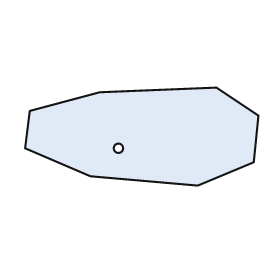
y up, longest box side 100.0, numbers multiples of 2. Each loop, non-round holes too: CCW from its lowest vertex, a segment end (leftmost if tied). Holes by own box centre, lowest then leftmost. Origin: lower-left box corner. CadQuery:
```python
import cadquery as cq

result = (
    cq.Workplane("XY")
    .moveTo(74.0, 0.0)
    .lineTo(98.0, 10.0)
    .lineTo(100.0, 30.0)
    .lineTo(82.0, 42.0)
    .lineTo(32.0, 40.0)
    .lineTo(2.0, 32.0)
    .lineTo(0.0, 16.0)
    .lineTo(28.0, 4.0)
    .close()
    .moveTo(40.0, 16.0)
    .circle(2.0)
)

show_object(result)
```